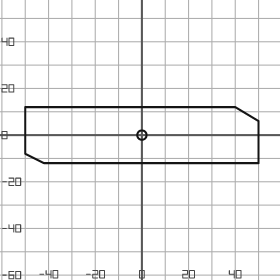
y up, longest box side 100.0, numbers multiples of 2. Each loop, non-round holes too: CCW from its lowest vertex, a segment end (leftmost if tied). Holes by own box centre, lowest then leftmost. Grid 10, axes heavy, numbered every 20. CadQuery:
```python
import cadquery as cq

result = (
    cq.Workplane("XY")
    .moveTo(-42.0, -12.0)
    .lineTo(50.0, -12.0)
    .lineTo(50.0, 6.0)
    .lineTo(40.0, 12.0)
    .lineTo(-50.0, 12.0)
    .lineTo(-50.0, -8.0)
    .close()
    .moveTo(0.0, 0.0)
    .circle(2.0)
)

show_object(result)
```